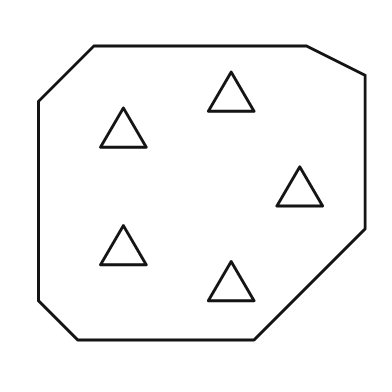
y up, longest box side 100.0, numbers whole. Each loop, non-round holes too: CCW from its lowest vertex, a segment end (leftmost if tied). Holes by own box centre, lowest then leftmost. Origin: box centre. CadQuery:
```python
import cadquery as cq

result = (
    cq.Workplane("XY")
    .moveTo(-38.0, -45.0)
    .lineTo(16.0, -45.0)
    .lineTo(50.0, -11.0)
    .lineTo(50.0, 36.0)
    .lineTo(32.0, 45.0)
    .lineTo(-33.0, 45.0)
    .lineTo(-50.0, 28.0)
    .lineTo(-50.0, -33.0)
    .close()
    .moveTo(2.0, -33.0)
    .lineTo(16.0, -33.0)
    .lineTo(9.0, -21.0)
    .close()
    .moveTo(-31.0, -22.0)
    .lineTo(-17.0, -22.0)
    .lineTo(-24.0, -10.0)
    .close()
    .moveTo(23.0, -4.0)
    .lineTo(37.0, -4.0)
    .lineTo(30.0, 8.0)
    .close()
    .moveTo(-31.0, 14.0)
    .lineTo(-17.0, 14.0)
    .lineTo(-24.0, 26.0)
    .close()
    .moveTo(2.0, 25.0)
    .lineTo(16.0, 25.0)
    .lineTo(9.0, 37.0)
    .close()
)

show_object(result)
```